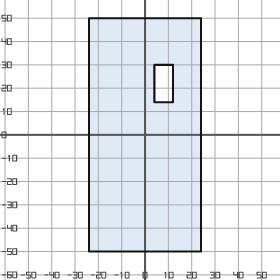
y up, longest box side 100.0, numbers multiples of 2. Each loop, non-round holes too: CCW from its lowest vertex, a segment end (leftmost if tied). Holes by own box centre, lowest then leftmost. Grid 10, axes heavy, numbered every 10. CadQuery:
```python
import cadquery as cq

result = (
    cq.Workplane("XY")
    .moveTo(-24.0, -50.0)
    .lineTo(24.0, -50.0)
    .lineTo(24.0, 50.0)
    .lineTo(-24.0, 50.0)
    .close()
    .moveTo(4.0, 14.0)
    .lineTo(12.0, 14.0)
    .lineTo(12.0, 30.0)
    .lineTo(4.0, 30.0)
    .close()
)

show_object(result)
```